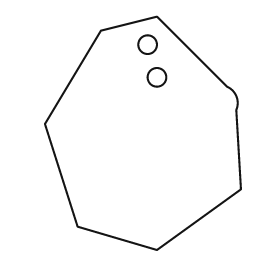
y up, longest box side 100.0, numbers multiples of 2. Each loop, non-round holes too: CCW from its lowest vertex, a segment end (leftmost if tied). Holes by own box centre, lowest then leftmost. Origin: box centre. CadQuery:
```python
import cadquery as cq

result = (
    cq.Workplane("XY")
    .moveTo(6.0, -50.0)
    .lineTo(42.0, -24.0)
    .lineTo(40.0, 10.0)
    .threePointArc((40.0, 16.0), (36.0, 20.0))
    .lineTo(6.0, 50.0)
    .lineTo(-18.0, 44.0)
    .lineTo(-42.0, 4.0)
    .lineTo(-28.0, -40.0)
    .close()
    .moveTo(6.0, 24.0)
    .circle(4.0)
    .moveTo(2.0, 38.0)
    .circle(4.0)
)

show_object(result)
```